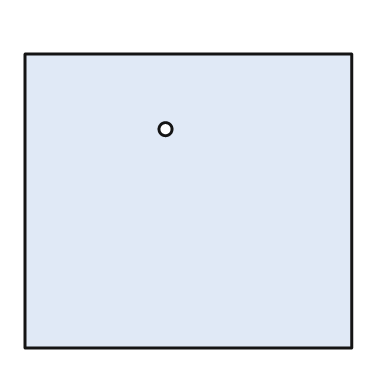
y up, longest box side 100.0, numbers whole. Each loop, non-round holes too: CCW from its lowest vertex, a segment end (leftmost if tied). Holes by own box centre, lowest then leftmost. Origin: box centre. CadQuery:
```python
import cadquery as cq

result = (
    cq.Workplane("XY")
    .moveTo(-50.0, -45.0)
    .lineTo(50.0, -45.0)
    .lineTo(50.0, 45.0)
    .lineTo(-50.0, 45.0)
    .close()
    .moveTo(-7.0, 22.0)
    .circle(2.0)
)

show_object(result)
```